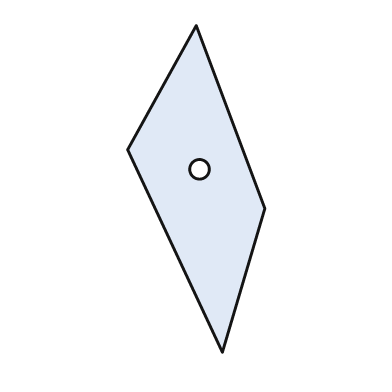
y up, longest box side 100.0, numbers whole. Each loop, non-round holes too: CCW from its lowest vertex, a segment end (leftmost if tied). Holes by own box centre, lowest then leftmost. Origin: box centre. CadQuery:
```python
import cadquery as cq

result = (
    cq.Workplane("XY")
    .moveTo(8.0, -50.0)
    .lineTo(21.0, -6.0)
    .lineTo(0.0, 50.0)
    .lineTo(-21.0, 12.0)
    .close()
    .moveTo(1.0, 6.0)
    .circle(3.0)
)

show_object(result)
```